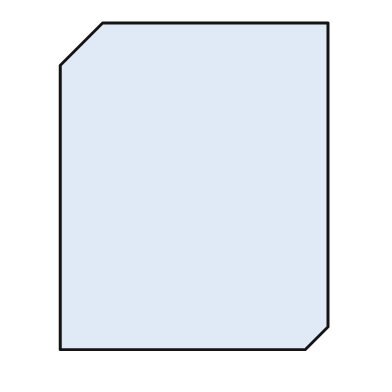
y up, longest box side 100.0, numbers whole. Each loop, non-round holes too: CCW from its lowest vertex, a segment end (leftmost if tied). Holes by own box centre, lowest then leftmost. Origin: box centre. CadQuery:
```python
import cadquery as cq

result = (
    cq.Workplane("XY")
    .moveTo(-41.0, -50.0)
    .lineTo(34.0, -50.0)
    .lineTo(41.0, -43.0)
    .lineTo(41.0, 50.0)
    .lineTo(-28.0, 50.0)
    .lineTo(-41.0, 37.0)
    .close()
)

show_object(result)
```